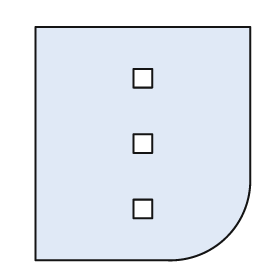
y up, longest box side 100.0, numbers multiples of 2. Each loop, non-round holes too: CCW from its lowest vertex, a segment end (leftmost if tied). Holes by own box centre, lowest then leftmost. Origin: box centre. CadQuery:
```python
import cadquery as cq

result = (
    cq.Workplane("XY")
    .moveTo(-46.0, -50.0)
    .lineTo(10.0, -50.0)
    .threePointArc((36.0, -40.0), (46.0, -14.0))
    .lineTo(46.0, 50.0)
    .lineTo(-46.0, 50.0)
    .close()
    .moveTo(-4.0, -32.0)
    .lineTo(4.0, -32.0)
    .lineTo(4.0, -24.0)
    .lineTo(-4.0, -24.0)
    .close()
    .moveTo(-4.0, -4.0)
    .lineTo(4.0, -4.0)
    .lineTo(4.0, 4.0)
    .lineTo(-4.0, 4.0)
    .close()
    .moveTo(-4.0, 24.0)
    .lineTo(4.0, 24.0)
    .lineTo(4.0, 32.0)
    .lineTo(-4.0, 32.0)
    .close()
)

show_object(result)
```